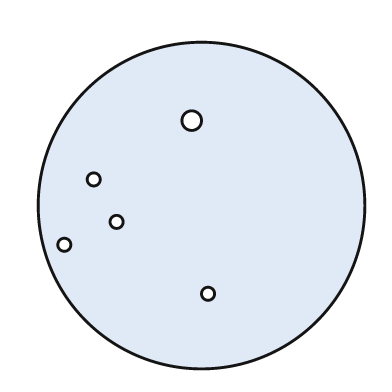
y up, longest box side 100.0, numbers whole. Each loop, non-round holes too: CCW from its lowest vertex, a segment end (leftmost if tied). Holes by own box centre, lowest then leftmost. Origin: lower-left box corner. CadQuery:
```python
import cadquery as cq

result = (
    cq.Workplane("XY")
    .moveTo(50.0, 50.0)
    .circle(50.0)
    .moveTo(52.0, 23.0)
    .circle(2.0)
    .moveTo(8.0, 38.0)
    .circle(2.0)
    .moveTo(24.0, 45.0)
    .circle(2.0)
    .moveTo(17.0, 58.0)
    .circle(2.0)
    .moveTo(47.0, 76.0)
    .circle(3.0)
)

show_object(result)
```